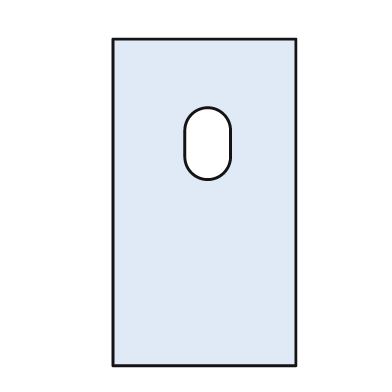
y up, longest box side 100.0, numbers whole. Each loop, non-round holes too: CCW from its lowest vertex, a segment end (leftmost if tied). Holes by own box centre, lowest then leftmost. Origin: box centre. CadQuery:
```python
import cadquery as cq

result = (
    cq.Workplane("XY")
    .moveTo(-28.0, -50.0)
    .lineTo(28.0, -50.0)
    .lineTo(28.0, 50.0)
    .lineTo(-28.0, 50.0)
    .close()
    .moveTo(-6.0, 14.0)
    .threePointArc((1.0, 7.0), (8.0, 14.0))
    .lineTo(8.0, 22.0)
    .threePointArc((1.0, 29.0), (-6.0, 22.0))
    .close()
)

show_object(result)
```